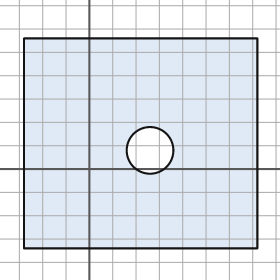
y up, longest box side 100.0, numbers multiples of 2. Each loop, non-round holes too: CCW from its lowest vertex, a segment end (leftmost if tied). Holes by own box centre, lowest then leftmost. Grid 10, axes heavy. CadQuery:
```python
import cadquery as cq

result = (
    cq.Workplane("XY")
    .moveTo(-28.0, -34.0)
    .lineTo(72.0, -34.0)
    .lineTo(72.0, 56.0)
    .lineTo(-28.0, 56.0)
    .close()
    .moveTo(26.0, 8.0)
    .circle(10.0)
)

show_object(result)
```